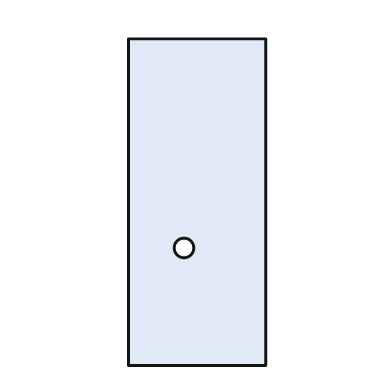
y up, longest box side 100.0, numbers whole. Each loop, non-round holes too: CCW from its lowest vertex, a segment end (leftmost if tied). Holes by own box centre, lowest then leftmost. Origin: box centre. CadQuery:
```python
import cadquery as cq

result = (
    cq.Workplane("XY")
    .moveTo(-21.0, -50.0)
    .lineTo(21.0, -50.0)
    .lineTo(21.0, 50.0)
    .lineTo(-21.0, 50.0)
    .close()
    .moveTo(-4.0, -14.0)
    .circle(3.0)
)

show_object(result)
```